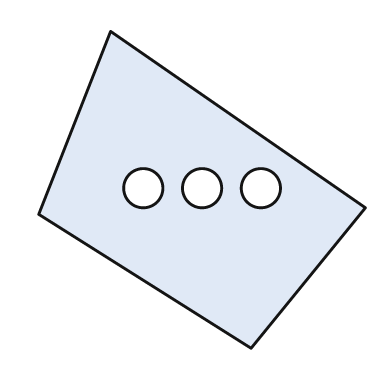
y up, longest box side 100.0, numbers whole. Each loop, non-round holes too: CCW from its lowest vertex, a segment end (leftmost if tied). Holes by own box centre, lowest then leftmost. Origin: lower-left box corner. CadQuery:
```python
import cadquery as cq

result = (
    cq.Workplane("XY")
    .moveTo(65.0, 0.0)
    .lineTo(100.0, 43.0)
    .lineTo(22.0, 97.0)
    .lineTo(0.0, 41.0)
    .close()
    .moveTo(32.0, 49.0)
    .circle(6.0)
    .moveTo(50.0, 49.0)
    .circle(6.0)
    .moveTo(68.0, 49.0)
    .circle(6.0)
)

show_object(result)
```